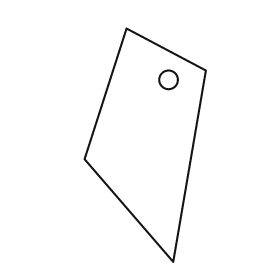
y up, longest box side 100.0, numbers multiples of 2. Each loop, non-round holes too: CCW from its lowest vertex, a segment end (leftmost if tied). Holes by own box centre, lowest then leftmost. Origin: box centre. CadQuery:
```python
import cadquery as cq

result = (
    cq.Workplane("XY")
    .moveTo(12.0, -50.0)
    .lineTo(26.0, 32.0)
    .lineTo(-8.0, 50.0)
    .lineTo(-26.0, -6.0)
    .close()
    .moveTo(10.0, 28.0)
    .circle(4.0)
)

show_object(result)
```